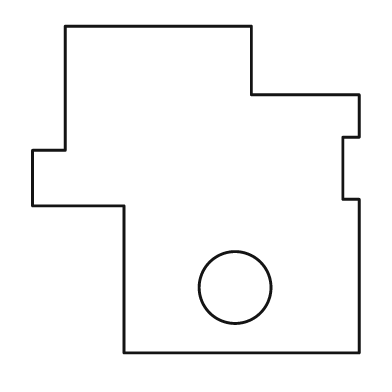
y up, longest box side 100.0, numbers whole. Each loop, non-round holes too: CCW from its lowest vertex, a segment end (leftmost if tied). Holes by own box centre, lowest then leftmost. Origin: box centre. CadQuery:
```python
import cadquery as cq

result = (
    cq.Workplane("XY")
    .moveTo(-22.0, -50.0)
    .lineTo(50.0, -50.0)
    .lineTo(50.0, -3.0)
    .lineTo(45.0, -3.0)
    .lineTo(45.0, 16.0)
    .lineTo(50.0, 16.0)
    .lineTo(50.0, 29.0)
    .lineTo(17.0, 29.0)
    .lineTo(17.0, 50.0)
    .lineTo(-40.0, 50.0)
    .lineTo(-40.0, 12.0)
    .lineTo(-50.0, 12.0)
    .lineTo(-50.0, -5.0)
    .lineTo(-22.0, -5.0)
    .close()
    .moveTo(12.0, -30.0)
    .circle(11.0)
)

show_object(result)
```